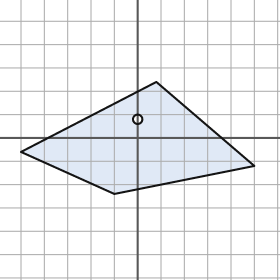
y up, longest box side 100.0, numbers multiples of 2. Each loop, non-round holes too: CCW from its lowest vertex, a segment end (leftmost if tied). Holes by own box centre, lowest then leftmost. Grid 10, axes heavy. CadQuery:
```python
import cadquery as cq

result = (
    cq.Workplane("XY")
    .moveTo(-10.0, -24.0)
    .lineTo(50.0, -12.0)
    .lineTo(8.0, 24.0)
    .lineTo(-50.0, -6.0)
    .close()
    .moveTo(0.0, 8.0)
    .circle(2.0)
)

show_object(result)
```